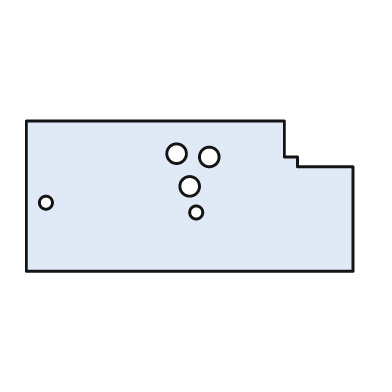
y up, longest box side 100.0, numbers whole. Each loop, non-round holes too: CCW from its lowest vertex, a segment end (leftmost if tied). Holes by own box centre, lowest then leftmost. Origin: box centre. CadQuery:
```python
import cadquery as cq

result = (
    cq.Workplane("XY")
    .moveTo(-50.0, -23.0)
    .lineTo(50.0, -23.0)
    .lineTo(50.0, 9.0)
    .lineTo(33.0, 9.0)
    .lineTo(33.0, 12.0)
    .lineTo(29.0, 12.0)
    .lineTo(29.0, 23.0)
    .lineTo(-50.0, 23.0)
    .close()
    .moveTo(2.0, -5.0)
    .circle(2.0)
    .moveTo(-44.0, -2.0)
    .circle(2.0)
    .moveTo(0.0, 3.0)
    .circle(3.0)
    .moveTo(6.0, 12.0)
    .circle(3.0)
    .moveTo(-4.0, 13.0)
    .circle(3.0)
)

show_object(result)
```